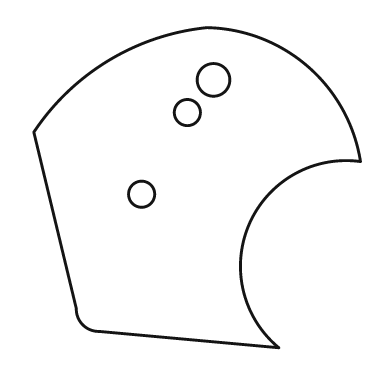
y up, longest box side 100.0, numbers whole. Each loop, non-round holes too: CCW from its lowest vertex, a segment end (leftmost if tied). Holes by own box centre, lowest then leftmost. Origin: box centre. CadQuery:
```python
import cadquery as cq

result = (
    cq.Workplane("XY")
    .moveTo(25.0, -49.0)
    .threePointArc((16.0, -11.0), (50.0, 8.0))
    .threePointArc((34.0, 37.0), (3.0, 49.0))
    .threePointArc((-27.0, 39.0), (-50.0, 17.0))
    .lineTo(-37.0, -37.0)
    .threePointArc((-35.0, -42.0), (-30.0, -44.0))
    .close()
    .moveTo(-17.0, -2.0)
    .circle(4.0)
    .moveTo(-3.0, 23.0)
    .circle(4.0)
    .moveTo(5.0, 33.0)
    .circle(5.0)
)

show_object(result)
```